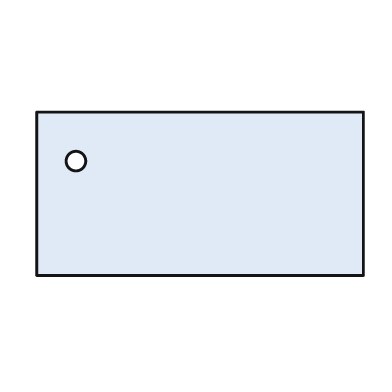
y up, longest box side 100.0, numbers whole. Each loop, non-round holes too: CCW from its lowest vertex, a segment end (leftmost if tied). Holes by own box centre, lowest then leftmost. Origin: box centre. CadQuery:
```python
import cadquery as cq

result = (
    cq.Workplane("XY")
    .moveTo(-50.0, -25.0)
    .lineTo(50.0, -25.0)
    .lineTo(50.0, 25.0)
    .lineTo(-50.0, 25.0)
    .close()
    .moveTo(-38.0, 10.0)
    .circle(3.0)
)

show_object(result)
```